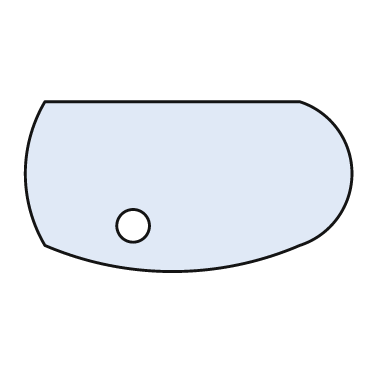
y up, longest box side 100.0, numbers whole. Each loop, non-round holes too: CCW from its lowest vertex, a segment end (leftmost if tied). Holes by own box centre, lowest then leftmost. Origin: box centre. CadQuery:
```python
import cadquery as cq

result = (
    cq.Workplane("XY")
    .moveTo(-44.0, -18.0)
    .threePointArc((-5.0, -26.0), (34.0, -18.0))
    .threePointArc((50.0, 4.0), (34.0, 26.0))
    .lineTo(-44.0, 26.0)
    .threePointArc((-50.0, 4.0), (-44.0, -18.0))
    .close()
    .moveTo(-17.0, -12.0)
    .circle(5.0)
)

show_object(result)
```